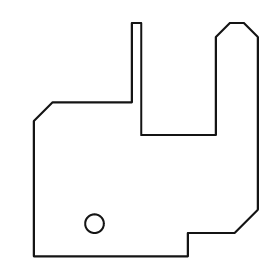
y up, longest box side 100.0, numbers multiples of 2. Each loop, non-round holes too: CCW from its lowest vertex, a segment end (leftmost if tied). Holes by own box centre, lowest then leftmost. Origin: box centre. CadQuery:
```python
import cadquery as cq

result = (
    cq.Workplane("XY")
    .moveTo(-48.0, -50.0)
    .lineTo(18.0, -50.0)
    .lineTo(18.0, -40.0)
    .lineTo(38.0, -40.0)
    .lineTo(48.0, -30.0)
    .lineTo(48.0, 44.0)
    .lineTo(42.0, 50.0)
    .lineTo(36.0, 50.0)
    .lineTo(30.0, 44.0)
    .lineTo(30.0, 2.0)
    .lineTo(-2.0, 2.0)
    .lineTo(-2.0, 50.0)
    .lineTo(-6.0, 50.0)
    .lineTo(-6.0, 16.0)
    .lineTo(-40.0, 16.0)
    .lineTo(-48.0, 8.0)
    .close()
    .moveTo(-22.0, -36.0)
    .circle(4.0)
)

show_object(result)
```